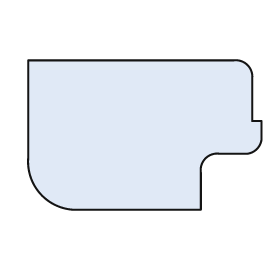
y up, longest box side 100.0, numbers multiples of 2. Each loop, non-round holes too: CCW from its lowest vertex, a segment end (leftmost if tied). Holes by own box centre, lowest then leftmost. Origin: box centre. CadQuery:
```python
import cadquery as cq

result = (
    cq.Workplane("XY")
    .moveTo(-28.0, -32.0)
    .lineTo(24.0, -32.0)
    .lineTo(24.0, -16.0)
    .threePointArc((26.0, -10.0), (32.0, -8.0))
    .lineTo(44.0, -8.0)
    .threePointArc((48.0, -6.0), (50.0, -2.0))
    .lineTo(50.0, 6.0)
    .lineTo(46.0, 6.0)
    .lineTo(46.0, 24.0)
    .threePointArc((44.0, 30.0), (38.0, 32.0))
    .lineTo(-50.0, 32.0)
    .lineTo(-50.0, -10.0)
    .threePointArc((-44.0, -26.0), (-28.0, -32.0))
    .close()
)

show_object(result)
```